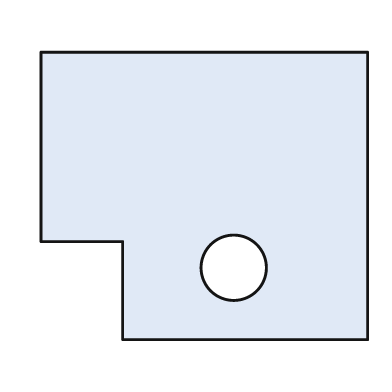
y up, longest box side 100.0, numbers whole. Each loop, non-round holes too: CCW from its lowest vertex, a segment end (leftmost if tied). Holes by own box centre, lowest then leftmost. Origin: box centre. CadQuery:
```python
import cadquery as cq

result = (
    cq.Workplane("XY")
    .moveTo(-25.0, -44.0)
    .lineTo(50.0, -44.0)
    .lineTo(50.0, 44.0)
    .lineTo(-50.0, 44.0)
    .lineTo(-50.0, -14.0)
    .lineTo(-25.0, -14.0)
    .close()
    .moveTo(9.0, -22.0)
    .circle(10.0)
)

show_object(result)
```